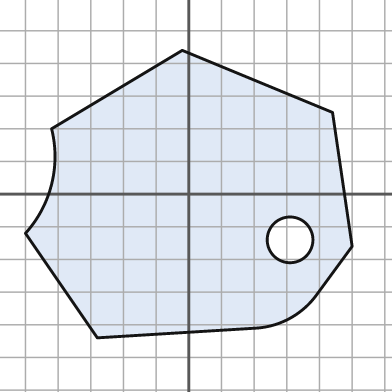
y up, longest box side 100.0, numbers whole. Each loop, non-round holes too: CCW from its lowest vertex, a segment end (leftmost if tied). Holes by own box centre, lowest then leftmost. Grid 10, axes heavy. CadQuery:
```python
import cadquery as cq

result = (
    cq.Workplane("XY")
    .moveTo(-28.0, -44.0)
    .lineTo(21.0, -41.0)
    .threePointArc((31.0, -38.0), (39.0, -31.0))
    .lineTo(50.0, -16.0)
    .lineTo(44.0, 25.0)
    .lineTo(-2.0, 44.0)
    .lineTo(-42.0, 20.0)
    .threePointArc((-42.0, 3.0), (-50.0, -12.0))
    .close()
    .moveTo(31.0, -14.0)
    .circle(7.0)
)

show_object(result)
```